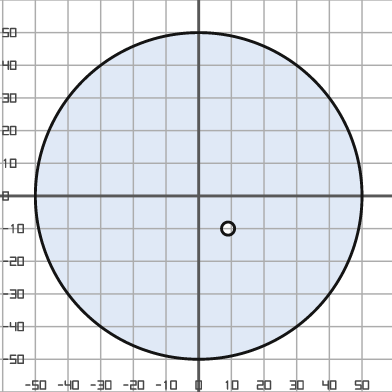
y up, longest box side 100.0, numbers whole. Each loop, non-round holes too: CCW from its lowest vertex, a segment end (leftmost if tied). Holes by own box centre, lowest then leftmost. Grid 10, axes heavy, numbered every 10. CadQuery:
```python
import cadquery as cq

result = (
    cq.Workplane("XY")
    .moveTo(0.0, 0.0)
    .circle(50.0)
    .moveTo(9.0, -10.0)
    .circle(2.0)
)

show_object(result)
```